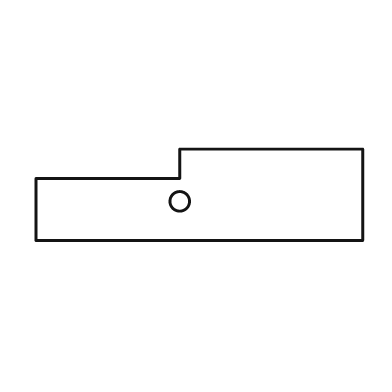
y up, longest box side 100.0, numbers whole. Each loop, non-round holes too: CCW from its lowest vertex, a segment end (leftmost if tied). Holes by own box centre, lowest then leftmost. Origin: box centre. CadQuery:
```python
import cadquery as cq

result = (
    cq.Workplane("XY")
    .moveTo(-50.0, -14.0)
    .lineTo(50.0, -14.0)
    .lineTo(50.0, 14.0)
    .lineTo(-6.0, 14.0)
    .lineTo(-6.0, 5.0)
    .lineTo(-50.0, 5.0)
    .close()
    .moveTo(-6.0, -2.0)
    .circle(3.0)
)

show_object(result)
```